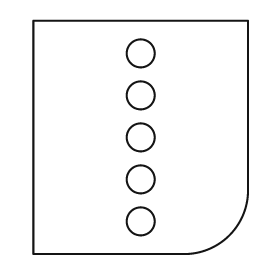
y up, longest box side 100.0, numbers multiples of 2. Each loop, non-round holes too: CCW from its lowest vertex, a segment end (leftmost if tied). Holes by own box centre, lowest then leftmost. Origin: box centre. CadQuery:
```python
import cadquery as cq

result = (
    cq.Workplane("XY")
    .moveTo(-46.0, -50.0)
    .lineTo(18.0, -50.0)
    .threePointArc((38.0, -42.0), (46.0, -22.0))
    .lineTo(46.0, 50.0)
    .lineTo(-46.0, 50.0)
    .close()
    .moveTo(0.0, -36.0)
    .circle(6.0)
    .moveTo(0.0, -18.0)
    .circle(6.0)
    .moveTo(0.0, 0.0)
    .circle(6.0)
    .moveTo(0.0, 18.0)
    .circle(6.0)
    .moveTo(0.0, 36.0)
    .circle(6.0)
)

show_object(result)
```